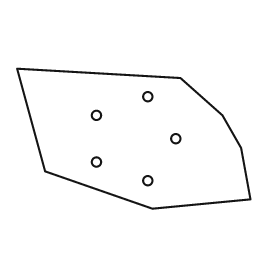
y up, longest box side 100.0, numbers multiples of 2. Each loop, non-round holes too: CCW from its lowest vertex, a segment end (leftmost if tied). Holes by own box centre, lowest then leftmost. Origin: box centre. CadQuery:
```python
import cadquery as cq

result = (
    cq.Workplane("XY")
    .moveTo(8.0, -30.0)
    .lineTo(50.0, -26.0)
    .lineTo(46.0, -4.0)
    .lineTo(38.0, 10.0)
    .lineTo(20.0, 26.0)
    .lineTo(-50.0, 30.0)
    .lineTo(-38.0, -14.0)
    .close()
    .moveTo(6.0, -18.0)
    .circle(2.0)
    .moveTo(-16.0, -10.0)
    .circle(2.0)
    .moveTo(18.0, 0.0)
    .circle(2.0)
    .moveTo(-16.0, 10.0)
    .circle(2.0)
    .moveTo(6.0, 18.0)
    .circle(2.0)
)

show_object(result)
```